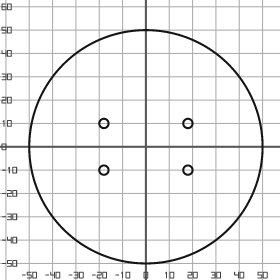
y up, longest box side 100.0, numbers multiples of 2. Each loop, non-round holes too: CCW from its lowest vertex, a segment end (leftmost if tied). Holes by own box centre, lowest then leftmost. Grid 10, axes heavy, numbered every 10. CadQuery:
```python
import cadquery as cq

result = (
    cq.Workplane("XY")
    .moveTo(0.0, 0.0)
    .circle(50.0)
    .moveTo(-18.0, -10.0)
    .circle(2.0)
    .moveTo(18.0, -10.0)
    .circle(2.0)
    .moveTo(-18.0, 10.0)
    .circle(2.0)
    .moveTo(18.0, 10.0)
    .circle(2.0)
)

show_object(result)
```